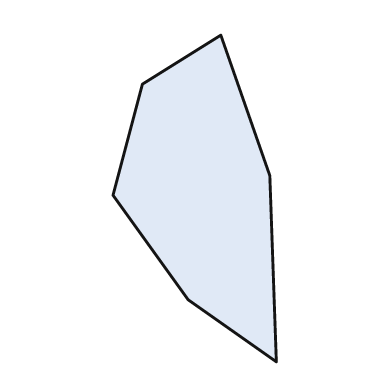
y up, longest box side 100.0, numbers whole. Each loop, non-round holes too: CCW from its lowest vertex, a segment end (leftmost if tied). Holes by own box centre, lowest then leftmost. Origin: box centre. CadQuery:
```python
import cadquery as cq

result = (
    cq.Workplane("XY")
    .moveTo(25.0, -50.0)
    .lineTo(23.0, 7.0)
    .lineTo(8.0, 50.0)
    .lineTo(-16.0, 35.0)
    .lineTo(-25.0, 1.0)
    .lineTo(-2.0, -31.0)
    .close()
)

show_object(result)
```